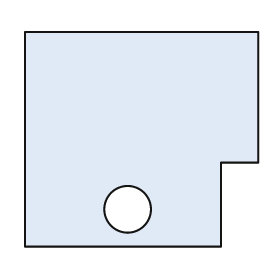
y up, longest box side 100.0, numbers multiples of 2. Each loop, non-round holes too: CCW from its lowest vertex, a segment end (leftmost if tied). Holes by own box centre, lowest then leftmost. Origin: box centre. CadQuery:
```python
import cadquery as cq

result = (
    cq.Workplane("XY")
    .moveTo(-50.0, -46.0)
    .lineTo(34.0, -46.0)
    .lineTo(34.0, -10.0)
    .lineTo(50.0, -10.0)
    .lineTo(50.0, 46.0)
    .lineTo(-50.0, 46.0)
    .close()
    .moveTo(-6.0, -30.0)
    .circle(10.0)
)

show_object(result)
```